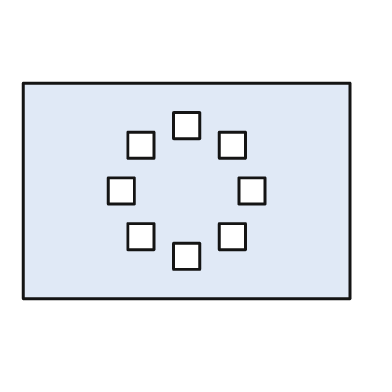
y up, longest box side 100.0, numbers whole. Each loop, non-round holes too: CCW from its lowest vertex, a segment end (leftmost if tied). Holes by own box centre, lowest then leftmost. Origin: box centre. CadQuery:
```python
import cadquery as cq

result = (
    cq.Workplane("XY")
    .moveTo(-50.0, -33.0)
    .lineTo(50.0, -33.0)
    .lineTo(50.0, 33.0)
    .lineTo(-50.0, 33.0)
    .close()
    .moveTo(-4.0, -24.0)
    .lineTo(4.0, -24.0)
    .lineTo(4.0, -16.0)
    .lineTo(-4.0, -16.0)
    .close()
    .moveTo(-18.0, -18.0)
    .lineTo(-10.0, -18.0)
    .lineTo(-10.0, -10.0)
    .lineTo(-18.0, -10.0)
    .close()
    .moveTo(10.0, -18.0)
    .lineTo(18.0, -18.0)
    .lineTo(18.0, -10.0)
    .lineTo(10.0, -10.0)
    .close()
    .moveTo(-24.0, -4.0)
    .lineTo(-16.0, -4.0)
    .lineTo(-16.0, 4.0)
    .lineTo(-24.0, 4.0)
    .close()
    .moveTo(16.0, -4.0)
    .lineTo(24.0, -4.0)
    .lineTo(24.0, 4.0)
    .lineTo(16.0, 4.0)
    .close()
    .moveTo(-18.0, 10.0)
    .lineTo(-10.0, 10.0)
    .lineTo(-10.0, 18.0)
    .lineTo(-18.0, 18.0)
    .close()
    .moveTo(10.0, 10.0)
    .lineTo(18.0, 10.0)
    .lineTo(18.0, 18.0)
    .lineTo(10.0, 18.0)
    .close()
    .moveTo(-4.0, 16.0)
    .lineTo(4.0, 16.0)
    .lineTo(4.0, 24.0)
    .lineTo(-4.0, 24.0)
    .close()
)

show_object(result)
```